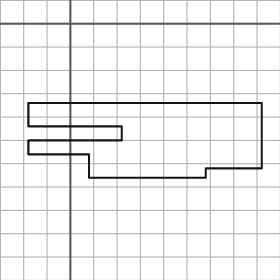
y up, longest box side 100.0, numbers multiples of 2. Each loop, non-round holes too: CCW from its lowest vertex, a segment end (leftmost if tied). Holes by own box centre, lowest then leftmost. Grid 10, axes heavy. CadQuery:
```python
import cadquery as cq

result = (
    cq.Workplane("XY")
    .moveTo(8.0, -66.0)
    .lineTo(58.0, -66.0)
    .lineTo(58.0, -62.0)
    .lineTo(82.0, -62.0)
    .lineTo(82.0, -34.0)
    .lineTo(-18.0, -34.0)
    .lineTo(-18.0, -44.0)
    .lineTo(22.0, -44.0)
    .lineTo(22.0, -50.0)
    .lineTo(-18.0, -50.0)
    .lineTo(-18.0, -56.0)
    .lineTo(8.0, -56.0)
    .close()
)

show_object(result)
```